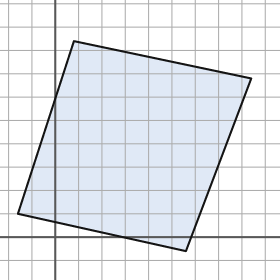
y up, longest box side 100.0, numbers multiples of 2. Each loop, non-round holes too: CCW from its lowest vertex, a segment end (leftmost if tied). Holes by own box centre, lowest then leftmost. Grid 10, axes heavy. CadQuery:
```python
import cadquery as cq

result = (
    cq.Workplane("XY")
    .moveTo(56.0, -6.0)
    .lineTo(84.0, 68.0)
    .lineTo(8.0, 84.0)
    .lineTo(-16.0, 10.0)
    .close()
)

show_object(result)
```